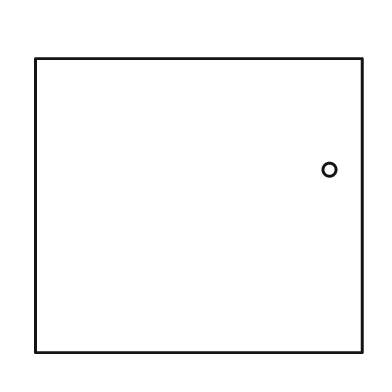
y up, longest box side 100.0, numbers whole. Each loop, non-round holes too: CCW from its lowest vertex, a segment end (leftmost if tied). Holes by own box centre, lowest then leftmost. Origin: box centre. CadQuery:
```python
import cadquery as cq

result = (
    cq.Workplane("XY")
    .moveTo(-50.0, -45.0)
    .lineTo(50.0, -45.0)
    .lineTo(50.0, 45.0)
    .lineTo(-50.0, 45.0)
    .close()
    .moveTo(40.0, 11.0)
    .circle(2.0)
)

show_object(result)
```